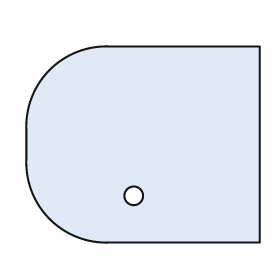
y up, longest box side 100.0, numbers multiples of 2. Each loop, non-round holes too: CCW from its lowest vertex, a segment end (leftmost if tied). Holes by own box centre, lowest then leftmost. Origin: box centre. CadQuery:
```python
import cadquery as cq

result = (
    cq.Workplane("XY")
    .moveTo(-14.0, -42.0)
    .lineTo(50.0, -42.0)
    .lineTo(50.0, 42.0)
    .lineTo(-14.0, 42.0)
    .threePointArc((-40.0, 32.0), (-50.0, 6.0))
    .lineTo(-50.0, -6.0)
    .threePointArc((-40.0, -32.0), (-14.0, -42.0))
    .close()
    .moveTo(-4.0, -22.0)
    .circle(4.0)
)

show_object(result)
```